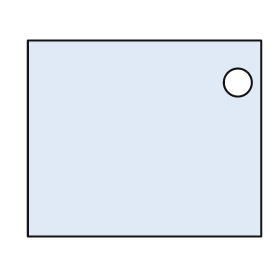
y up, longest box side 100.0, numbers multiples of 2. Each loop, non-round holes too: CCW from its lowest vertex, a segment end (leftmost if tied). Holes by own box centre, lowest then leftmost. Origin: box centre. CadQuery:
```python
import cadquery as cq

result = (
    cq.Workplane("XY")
    .moveTo(-50.0, -42.0)
    .lineTo(50.0, -42.0)
    .lineTo(50.0, 42.0)
    .lineTo(-50.0, 42.0)
    .close()
    .moveTo(40.0, 24.0)
    .circle(6.0)
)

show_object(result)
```